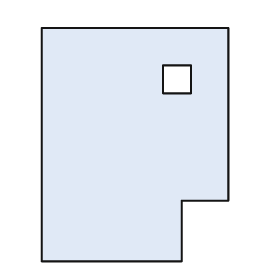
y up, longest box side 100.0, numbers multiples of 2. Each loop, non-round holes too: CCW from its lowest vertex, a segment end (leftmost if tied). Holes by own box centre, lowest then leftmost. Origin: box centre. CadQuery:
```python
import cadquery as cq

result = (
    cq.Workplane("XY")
    .moveTo(-40.0, -50.0)
    .lineTo(20.0, -50.0)
    .lineTo(20.0, -24.0)
    .lineTo(40.0, -24.0)
    .lineTo(40.0, 50.0)
    .lineTo(-40.0, 50.0)
    .close()
    .moveTo(12.0, 22.0)
    .lineTo(24.0, 22.0)
    .lineTo(24.0, 34.0)
    .lineTo(12.0, 34.0)
    .close()
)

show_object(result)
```